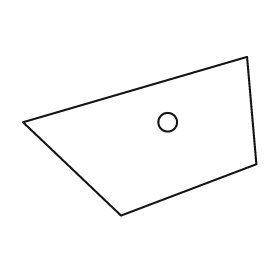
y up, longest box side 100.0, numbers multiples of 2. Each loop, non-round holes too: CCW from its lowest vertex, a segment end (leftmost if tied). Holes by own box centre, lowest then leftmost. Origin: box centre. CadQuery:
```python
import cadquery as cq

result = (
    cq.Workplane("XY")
    .moveTo(-8.0, -34.0)
    .lineTo(50.0, -12.0)
    .lineTo(46.0, 34.0)
    .lineTo(-50.0, 6.0)
    .close()
    .moveTo(12.0, 6.0)
    .circle(4.0)
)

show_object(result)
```